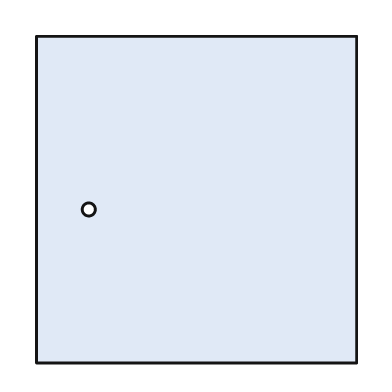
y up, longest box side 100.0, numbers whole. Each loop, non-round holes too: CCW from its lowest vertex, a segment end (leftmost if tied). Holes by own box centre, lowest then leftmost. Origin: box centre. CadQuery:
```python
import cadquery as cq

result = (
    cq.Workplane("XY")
    .moveTo(-49.0, -50.0)
    .lineTo(49.0, -50.0)
    .lineTo(49.0, 50.0)
    .lineTo(-49.0, 50.0)
    .close()
    .moveTo(-33.0, -3.0)
    .circle(2.0)
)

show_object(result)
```